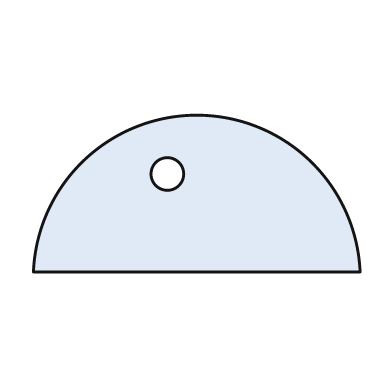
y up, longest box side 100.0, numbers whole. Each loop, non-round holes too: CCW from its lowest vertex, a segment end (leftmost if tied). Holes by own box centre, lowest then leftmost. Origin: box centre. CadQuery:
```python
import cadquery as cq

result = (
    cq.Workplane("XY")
    .moveTo(-50.0, -24.0)
    .lineTo(50.0, -24.0)
    .threePointArc((0.0, 24.0), (-50.0, -24.0))
    .close()
    .moveTo(-9.0, 6.0)
    .circle(5.0)
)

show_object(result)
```